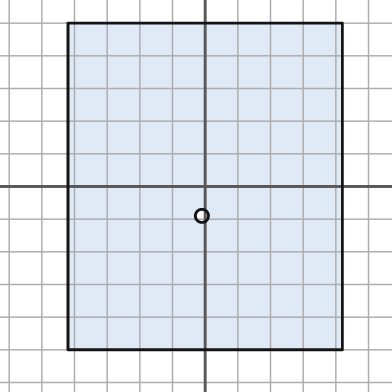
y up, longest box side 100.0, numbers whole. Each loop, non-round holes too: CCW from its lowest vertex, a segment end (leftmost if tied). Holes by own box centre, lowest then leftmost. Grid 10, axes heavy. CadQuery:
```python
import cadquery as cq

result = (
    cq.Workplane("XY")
    .moveTo(-42.0, -50.0)
    .lineTo(42.0, -50.0)
    .lineTo(42.0, 50.0)
    .lineTo(-42.0, 50.0)
    .close()
    .moveTo(-1.0, -9.0)
    .circle(2.0)
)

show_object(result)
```